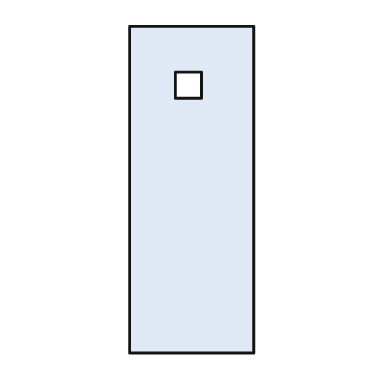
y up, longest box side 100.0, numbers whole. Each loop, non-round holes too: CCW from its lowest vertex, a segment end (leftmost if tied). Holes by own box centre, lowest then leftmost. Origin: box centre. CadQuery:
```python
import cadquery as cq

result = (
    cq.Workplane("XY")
    .moveTo(-19.0, -50.0)
    .lineTo(19.0, -50.0)
    .lineTo(19.0, 50.0)
    .lineTo(-19.0, 50.0)
    .close()
    .moveTo(-5.0, 28.0)
    .lineTo(3.0, 28.0)
    .lineTo(3.0, 36.0)
    .lineTo(-5.0, 36.0)
    .close()
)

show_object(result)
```